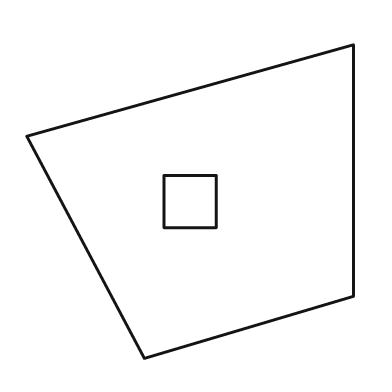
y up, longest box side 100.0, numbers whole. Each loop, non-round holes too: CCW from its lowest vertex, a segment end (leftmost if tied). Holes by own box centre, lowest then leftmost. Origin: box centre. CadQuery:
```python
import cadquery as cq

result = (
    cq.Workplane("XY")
    .moveTo(-14.0, -48.0)
    .lineTo(50.0, -29.0)
    .lineTo(50.0, 48.0)
    .lineTo(-50.0, 20.0)
    .close()
    .moveTo(-8.0, -8.0)
    .lineTo(8.0, -8.0)
    .lineTo(8.0, 8.0)
    .lineTo(-8.0, 8.0)
    .close()
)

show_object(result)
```